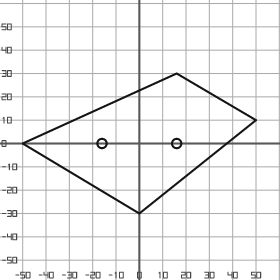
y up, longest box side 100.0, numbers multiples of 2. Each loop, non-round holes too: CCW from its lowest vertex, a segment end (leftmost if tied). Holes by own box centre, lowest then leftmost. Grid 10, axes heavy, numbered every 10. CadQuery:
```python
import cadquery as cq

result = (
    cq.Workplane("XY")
    .moveTo(0.0, -30.0)
    .lineTo(50.0, 10.0)
    .lineTo(16.0, 30.0)
    .lineTo(-50.0, 0.0)
    .close()
    .moveTo(-16.0, 0.0)
    .circle(2.0)
    .moveTo(16.0, 0.0)
    .circle(2.0)
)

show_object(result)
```